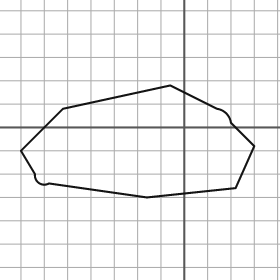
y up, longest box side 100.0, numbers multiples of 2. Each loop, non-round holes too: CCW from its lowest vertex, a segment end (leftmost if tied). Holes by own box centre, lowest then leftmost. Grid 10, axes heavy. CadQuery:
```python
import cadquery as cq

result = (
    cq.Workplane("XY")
    .moveTo(-16.0, -30.0)
    .lineTo(22.0, -26.0)
    .lineTo(30.0, -8.0)
    .lineTo(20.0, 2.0)
    .threePointArc((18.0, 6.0), (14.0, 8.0))
    .lineTo(-6.0, 18.0)
    .lineTo(-52.0, 8.0)
    .lineTo(-70.0, -10.0)
    .lineTo(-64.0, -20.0)
    .threePointArc((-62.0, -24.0), (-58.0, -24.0))
    .close()
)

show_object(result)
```